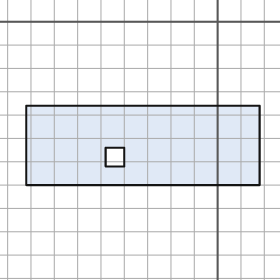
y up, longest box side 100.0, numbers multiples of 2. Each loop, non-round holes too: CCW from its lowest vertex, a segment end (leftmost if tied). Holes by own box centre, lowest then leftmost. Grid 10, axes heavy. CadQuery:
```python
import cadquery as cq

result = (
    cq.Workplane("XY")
    .moveTo(-82.0, -70.0)
    .lineTo(18.0, -70.0)
    .lineTo(18.0, -36.0)
    .lineTo(-82.0, -36.0)
    .close()
    .moveTo(-48.0, -62.0)
    .lineTo(-40.0, -62.0)
    .lineTo(-40.0, -54.0)
    .lineTo(-48.0, -54.0)
    .close()
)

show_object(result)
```